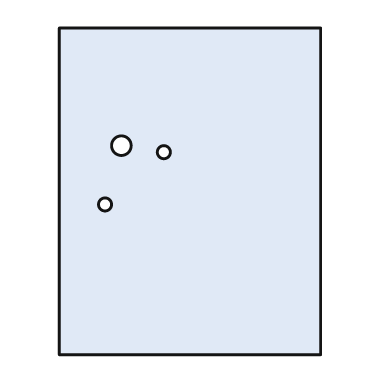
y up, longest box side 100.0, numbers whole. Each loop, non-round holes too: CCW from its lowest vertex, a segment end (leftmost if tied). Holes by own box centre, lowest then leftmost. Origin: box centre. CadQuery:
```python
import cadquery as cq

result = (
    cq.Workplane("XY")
    .moveTo(-40.0, -50.0)
    .lineTo(40.0, -50.0)
    .lineTo(40.0, 50.0)
    .lineTo(-40.0, 50.0)
    .close()
    .moveTo(-26.0, -4.0)
    .circle(2.0)
    .moveTo(-8.0, 12.0)
    .circle(2.0)
    .moveTo(-21.0, 14.0)
    .circle(3.0)
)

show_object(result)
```